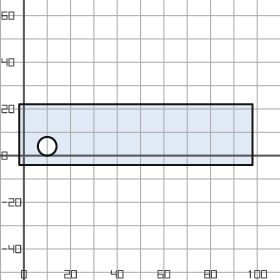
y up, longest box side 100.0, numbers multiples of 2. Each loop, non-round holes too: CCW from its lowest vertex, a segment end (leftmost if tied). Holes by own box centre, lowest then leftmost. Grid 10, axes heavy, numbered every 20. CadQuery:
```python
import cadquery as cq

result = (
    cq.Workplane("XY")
    .moveTo(-2.0, -4.0)
    .lineTo(98.0, -4.0)
    .lineTo(98.0, 22.0)
    .lineTo(-2.0, 22.0)
    .close()
    .moveTo(10.0, 4.0)
    .circle(4.0)
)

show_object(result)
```